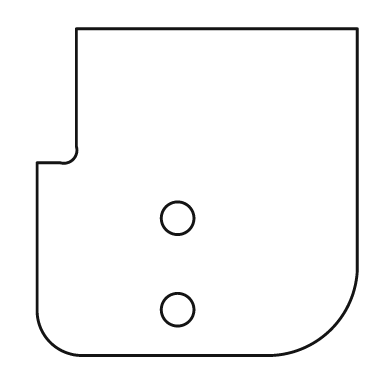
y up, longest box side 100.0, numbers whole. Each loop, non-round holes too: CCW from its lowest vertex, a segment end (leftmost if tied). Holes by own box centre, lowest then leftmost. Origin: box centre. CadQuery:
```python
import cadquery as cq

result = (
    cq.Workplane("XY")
    .moveTo(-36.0, -50.0)
    .lineTo(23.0, -50.0)
    .threePointArc((41.0, -42.0), (49.0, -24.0))
    .lineTo(49.0, 50.0)
    .lineTo(-37.0, 50.0)
    .lineTo(-37.0, 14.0)
    .threePointArc((-38.0, 10.0), (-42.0, 9.0))
    .lineTo(-49.0, 9.0)
    .lineTo(-49.0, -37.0)
    .threePointArc((-45.0, -46.0), (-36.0, -50.0))
    .close()
    .moveTo(-6.0, -36.0)
    .circle(5.0)
    .moveTo(-6.0, -8.0)
    .circle(5.0)
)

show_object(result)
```